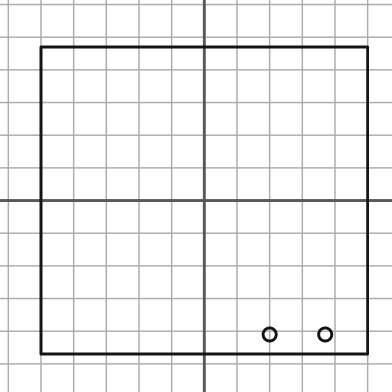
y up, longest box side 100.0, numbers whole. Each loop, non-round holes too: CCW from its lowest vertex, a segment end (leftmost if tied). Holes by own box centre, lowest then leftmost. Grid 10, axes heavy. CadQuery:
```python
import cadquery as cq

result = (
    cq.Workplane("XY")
    .moveTo(-50.0, -47.0)
    .lineTo(50.0, -47.0)
    .lineTo(50.0, 47.0)
    .lineTo(-50.0, 47.0)
    .close()
    .moveTo(20.0, -41.0)
    .circle(2.0)
    .moveTo(37.0, -41.0)
    .circle(2.0)
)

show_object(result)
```